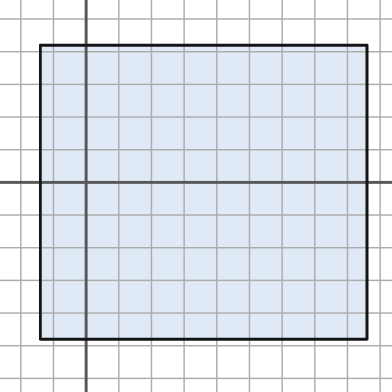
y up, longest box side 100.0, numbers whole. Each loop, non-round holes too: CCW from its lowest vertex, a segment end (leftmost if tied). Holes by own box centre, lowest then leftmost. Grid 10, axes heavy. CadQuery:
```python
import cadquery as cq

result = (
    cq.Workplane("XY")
    .moveTo(-14.0, -48.0)
    .lineTo(86.0, -48.0)
    .lineTo(86.0, 42.0)
    .lineTo(-14.0, 42.0)
    .close()
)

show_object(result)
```